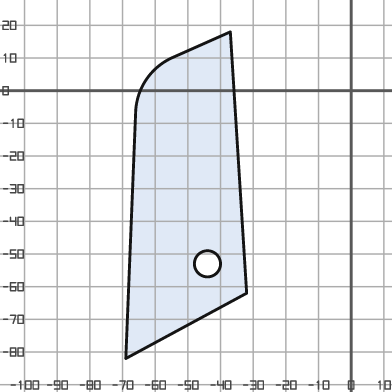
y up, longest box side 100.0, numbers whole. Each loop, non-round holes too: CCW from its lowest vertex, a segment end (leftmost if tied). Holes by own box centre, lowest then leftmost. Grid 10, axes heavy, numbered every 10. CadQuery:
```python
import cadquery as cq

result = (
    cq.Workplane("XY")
    .moveTo(-69.0, -82.0)
    .lineTo(-32.0, -62.0)
    .lineTo(-37.0, 18.0)
    .lineTo(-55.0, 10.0)
    .threePointArc((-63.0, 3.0), (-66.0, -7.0))
    .close()
    .moveTo(-44.0, -53.0)
    .circle(4.0)
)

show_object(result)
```